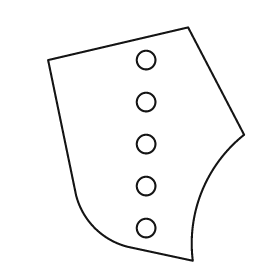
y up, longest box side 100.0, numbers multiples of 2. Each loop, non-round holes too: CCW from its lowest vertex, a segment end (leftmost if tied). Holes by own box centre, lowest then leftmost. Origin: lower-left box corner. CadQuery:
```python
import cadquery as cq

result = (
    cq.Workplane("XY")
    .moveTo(62.0, 0.0)
    .threePointArc((66.0, 30.0), (84.0, 54.0))
    .lineTo(60.0, 100.0)
    .lineTo(0.0, 86.0)
    .lineTo(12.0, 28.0)
    .threePointArc((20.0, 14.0), (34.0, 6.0))
    .close()
    .moveTo(42.0, 14.0)
    .circle(4.0)
    .moveTo(42.0, 32.0)
    .circle(4.0)
    .moveTo(42.0, 50.0)
    .circle(4.0)
    .moveTo(42.0, 68.0)
    .circle(4.0)
    .moveTo(42.0, 86.0)
    .circle(4.0)
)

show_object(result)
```